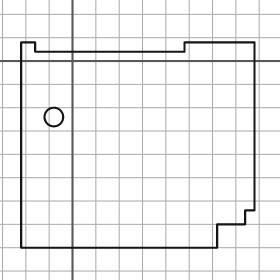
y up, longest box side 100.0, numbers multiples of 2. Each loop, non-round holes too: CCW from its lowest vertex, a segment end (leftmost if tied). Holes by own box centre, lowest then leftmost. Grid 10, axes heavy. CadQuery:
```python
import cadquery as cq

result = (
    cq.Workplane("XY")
    .moveTo(-22.0, -80.0)
    .lineTo(62.0, -80.0)
    .lineTo(62.0, -70.0)
    .lineTo(74.0, -70.0)
    .lineTo(74.0, -64.0)
    .lineTo(78.0, -64.0)
    .lineTo(78.0, 8.0)
    .lineTo(48.0, 8.0)
    .lineTo(48.0, 4.0)
    .lineTo(-16.0, 4.0)
    .lineTo(-16.0, 8.0)
    .lineTo(-22.0, 8.0)
    .close()
    .moveTo(-8.0, -24.0)
    .circle(4.0)
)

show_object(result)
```